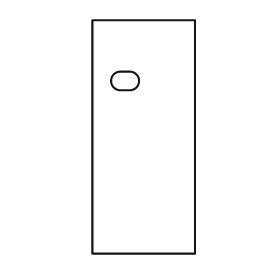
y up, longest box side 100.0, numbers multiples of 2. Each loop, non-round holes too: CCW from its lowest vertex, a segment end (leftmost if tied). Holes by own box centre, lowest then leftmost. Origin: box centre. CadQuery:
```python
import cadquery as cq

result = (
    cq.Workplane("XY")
    .moveTo(-22.0, -50.0)
    .lineTo(22.0, -50.0)
    .lineTo(22.0, 50.0)
    .lineTo(-22.0, 50.0)
    .close()
    .moveTo(-10.0, 20.0)
    .lineTo(-6.0, 20.0)
    .threePointArc((-2.0, 24.0), (-6.0, 28.0))
    .lineTo(-10.0, 28.0)
    .threePointArc((-14.0, 24.0), (-10.0, 20.0))
    .close()
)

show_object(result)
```